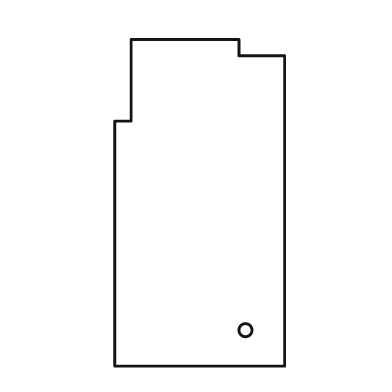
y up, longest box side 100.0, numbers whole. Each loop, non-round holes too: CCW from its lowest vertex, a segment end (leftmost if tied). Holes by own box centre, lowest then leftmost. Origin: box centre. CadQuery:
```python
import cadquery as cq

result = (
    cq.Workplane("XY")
    .moveTo(-26.0, -50.0)
    .lineTo(26.0, -50.0)
    .lineTo(26.0, 45.0)
    .lineTo(12.0, 45.0)
    .lineTo(12.0, 50.0)
    .lineTo(-21.0, 50.0)
    .lineTo(-21.0, 25.0)
    .lineTo(-26.0, 25.0)
    .close()
    .moveTo(14.0, -39.0)
    .circle(2.0)
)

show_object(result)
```